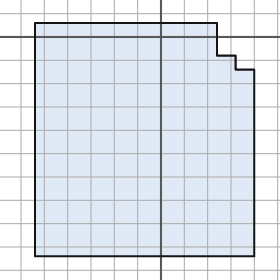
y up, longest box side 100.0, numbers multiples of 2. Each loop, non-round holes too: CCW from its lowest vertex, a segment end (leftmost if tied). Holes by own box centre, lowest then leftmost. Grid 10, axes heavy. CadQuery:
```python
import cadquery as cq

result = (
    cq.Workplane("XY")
    .moveTo(-54.0, -94.0)
    .lineTo(40.0, -94.0)
    .lineTo(40.0, -14.0)
    .lineTo(32.0, -14.0)
    .lineTo(32.0, -8.0)
    .lineTo(24.0, -8.0)
    .lineTo(24.0, 6.0)
    .lineTo(-54.0, 6.0)
    .close()
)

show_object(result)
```